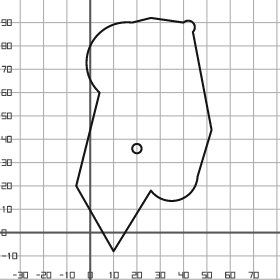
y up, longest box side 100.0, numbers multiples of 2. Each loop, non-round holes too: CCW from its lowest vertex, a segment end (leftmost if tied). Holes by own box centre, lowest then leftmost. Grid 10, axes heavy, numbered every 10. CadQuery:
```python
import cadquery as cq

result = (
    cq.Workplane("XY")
    .moveTo(10.0, -8.0)
    .lineTo(26.0, 18.0)
    .threePointArc((38.0, 14.0), (46.0, 24.0))
    .lineTo(52.0, 44.0)
    .lineTo(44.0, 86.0)
    .threePointArc((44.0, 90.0), (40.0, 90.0))
    .lineTo(26.0, 92.0)
    .lineTo(18.0, 90.0)
    .threePointArc((0.0, 80.0), (4.0, 60.0))
    .lineTo(-6.0, 20.0)
    .close()
    .moveTo(20.0, 36.0)
    .circle(2.0)
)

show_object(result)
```